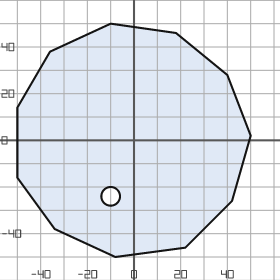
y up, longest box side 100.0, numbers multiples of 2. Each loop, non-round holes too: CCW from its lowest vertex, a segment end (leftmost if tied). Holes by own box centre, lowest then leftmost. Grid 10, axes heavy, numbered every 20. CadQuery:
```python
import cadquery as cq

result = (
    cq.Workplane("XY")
    .moveTo(-8.0, -50.0)
    .lineTo(22.0, -46.0)
    .lineTo(42.0, -26.0)
    .lineTo(50.0, 2.0)
    .lineTo(40.0, 28.0)
    .lineTo(18.0, 46.0)
    .lineTo(-10.0, 50.0)
    .lineTo(-36.0, 38.0)
    .lineTo(-50.0, 14.0)
    .lineTo(-50.0, -16.0)
    .lineTo(-34.0, -38.0)
    .close()
    .moveTo(-10.0, -24.0)
    .circle(4.0)
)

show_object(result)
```